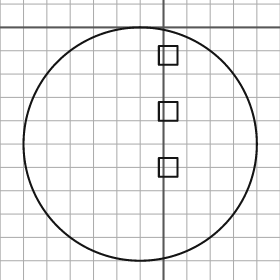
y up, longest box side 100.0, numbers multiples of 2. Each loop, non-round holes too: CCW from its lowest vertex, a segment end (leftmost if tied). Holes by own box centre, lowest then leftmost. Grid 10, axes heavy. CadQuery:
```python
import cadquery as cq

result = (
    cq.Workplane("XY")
    .moveTo(-10.0, -50.0)
    .circle(50.0)
    .moveTo(-2.0, -64.0)
    .lineTo(6.0, -64.0)
    .lineTo(6.0, -56.0)
    .lineTo(-2.0, -56.0)
    .close()
    .moveTo(-2.0, -40.0)
    .lineTo(6.0, -40.0)
    .lineTo(6.0, -32.0)
    .lineTo(-2.0, -32.0)
    .close()
    .moveTo(-2.0, -16.0)
    .lineTo(6.0, -16.0)
    .lineTo(6.0, -8.0)
    .lineTo(-2.0, -8.0)
    .close()
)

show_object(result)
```